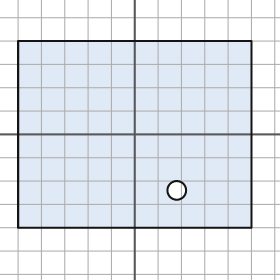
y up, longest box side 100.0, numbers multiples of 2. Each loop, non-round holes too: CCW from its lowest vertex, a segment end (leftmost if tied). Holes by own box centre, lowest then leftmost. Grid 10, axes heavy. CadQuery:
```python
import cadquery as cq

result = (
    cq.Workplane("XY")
    .moveTo(-50.0, -40.0)
    .lineTo(50.0, -40.0)
    .lineTo(50.0, 40.0)
    .lineTo(-50.0, 40.0)
    .close()
    .moveTo(18.0, -24.0)
    .circle(4.0)
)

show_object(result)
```